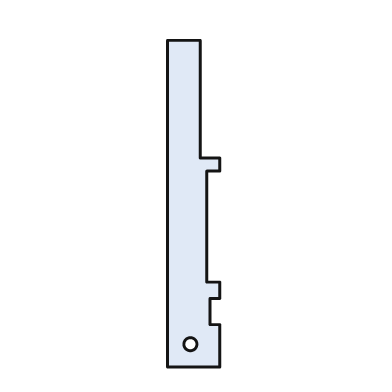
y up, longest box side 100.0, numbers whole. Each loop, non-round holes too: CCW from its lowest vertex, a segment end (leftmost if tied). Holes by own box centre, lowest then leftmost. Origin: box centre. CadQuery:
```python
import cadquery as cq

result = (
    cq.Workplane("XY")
    .moveTo(-8.0, -50.0)
    .lineTo(8.0, -50.0)
    .lineTo(8.0, -37.0)
    .lineTo(5.0, -37.0)
    .lineTo(5.0, -29.0)
    .lineTo(8.0, -29.0)
    .lineTo(8.0, -24.0)
    .lineTo(4.0, -24.0)
    .lineTo(4.0, 10.0)
    .lineTo(8.0, 10.0)
    .lineTo(8.0, 14.0)
    .lineTo(2.0, 14.0)
    .lineTo(2.0, 50.0)
    .lineTo(-8.0, 50.0)
    .close()
    .moveTo(-1.0, -43.0)
    .circle(2.0)
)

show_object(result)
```